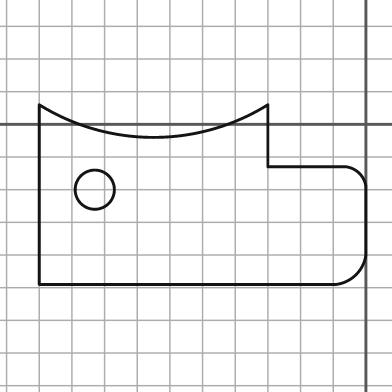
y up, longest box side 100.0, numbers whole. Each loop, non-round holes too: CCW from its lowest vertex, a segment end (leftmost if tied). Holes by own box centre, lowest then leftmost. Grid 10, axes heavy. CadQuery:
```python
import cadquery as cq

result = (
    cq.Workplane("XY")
    .moveTo(-100.0, -49.0)
    .lineTo(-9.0, -49.0)
    .threePointArc((-3.0, -46.0), (0.0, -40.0))
    .lineTo(0.0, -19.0)
    .threePointArc((-2.0, -15.0), (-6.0, -13.0))
    .lineTo(-30.0, -13.0)
    .lineTo(-30.0, 6.0)
    .threePointArc((-65.0, -4.0), (-100.0, 6.0))
    .close()
    .moveTo(-83.0, -20.0)
    .circle(6.0)
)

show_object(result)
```